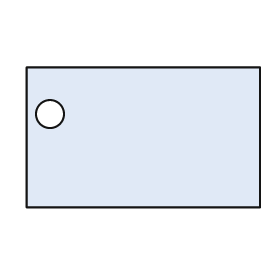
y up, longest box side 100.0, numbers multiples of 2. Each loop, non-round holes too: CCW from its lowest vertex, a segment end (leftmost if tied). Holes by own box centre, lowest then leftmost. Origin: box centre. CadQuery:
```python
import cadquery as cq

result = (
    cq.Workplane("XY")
    .moveTo(-50.0, -30.0)
    .lineTo(50.0, -30.0)
    .lineTo(50.0, 30.0)
    .lineTo(-50.0, 30.0)
    .close()
    .moveTo(-40.0, 10.0)
    .circle(6.0)
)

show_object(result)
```